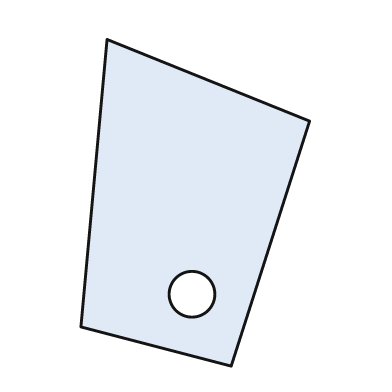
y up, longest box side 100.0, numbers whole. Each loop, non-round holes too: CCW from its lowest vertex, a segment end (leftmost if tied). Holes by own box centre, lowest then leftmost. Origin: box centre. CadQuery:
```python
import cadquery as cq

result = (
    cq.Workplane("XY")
    .moveTo(11.0, -50.0)
    .lineTo(35.0, 25.0)
    .lineTo(-27.0, 50.0)
    .lineTo(-35.0, -38.0)
    .close()
    .moveTo(-1.0, -28.0)
    .circle(7.0)
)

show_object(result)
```